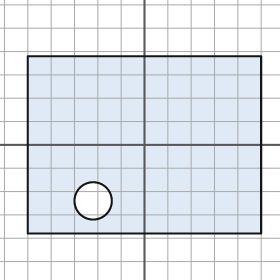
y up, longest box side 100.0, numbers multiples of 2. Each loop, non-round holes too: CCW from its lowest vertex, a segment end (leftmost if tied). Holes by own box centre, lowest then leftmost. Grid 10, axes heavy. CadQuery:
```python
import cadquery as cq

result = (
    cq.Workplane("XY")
    .moveTo(-50.0, -38.0)
    .lineTo(50.0, -38.0)
    .lineTo(50.0, 38.0)
    .lineTo(-50.0, 38.0)
    .close()
    .moveTo(-22.0, -24.0)
    .circle(8.0)
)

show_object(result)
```